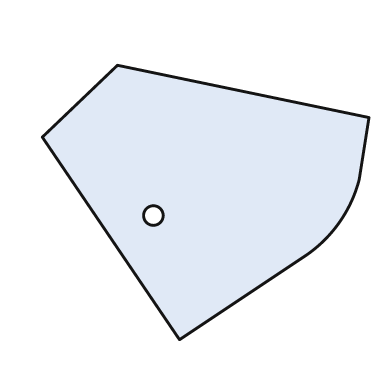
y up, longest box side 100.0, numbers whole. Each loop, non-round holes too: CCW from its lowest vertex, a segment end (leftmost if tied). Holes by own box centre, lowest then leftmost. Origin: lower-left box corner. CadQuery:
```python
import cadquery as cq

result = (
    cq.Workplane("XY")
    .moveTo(42.0, 0.0)
    .lineTo(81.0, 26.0)
    .threePointArc((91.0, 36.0), (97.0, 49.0))
    .lineTo(100.0, 68.0)
    .lineTo(23.0, 84.0)
    .lineTo(0.0, 62.0)
    .close()
    .moveTo(34.0, 38.0)
    .circle(3.0)
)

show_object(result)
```